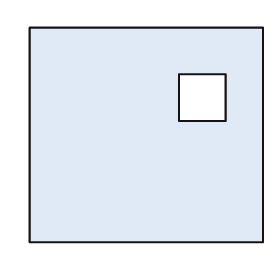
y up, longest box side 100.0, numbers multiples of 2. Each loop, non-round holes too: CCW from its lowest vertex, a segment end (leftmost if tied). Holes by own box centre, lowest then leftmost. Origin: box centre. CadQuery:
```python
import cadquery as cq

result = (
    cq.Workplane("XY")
    .moveTo(-50.0, -46.0)
    .lineTo(50.0, -46.0)
    .lineTo(50.0, 46.0)
    .lineTo(-50.0, 46.0)
    .close()
    .moveTo(14.0, 6.0)
    .lineTo(34.0, 6.0)
    .lineTo(34.0, 26.0)
    .lineTo(14.0, 26.0)
    .close()
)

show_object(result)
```